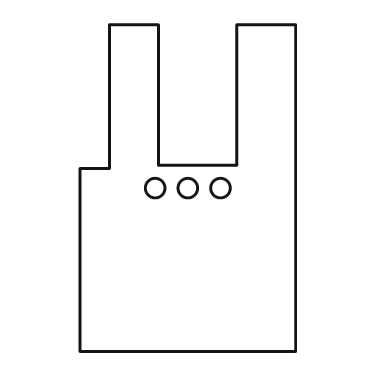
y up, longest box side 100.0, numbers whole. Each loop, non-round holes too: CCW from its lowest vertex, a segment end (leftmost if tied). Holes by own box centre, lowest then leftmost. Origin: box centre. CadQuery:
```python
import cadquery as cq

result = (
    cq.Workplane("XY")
    .moveTo(-33.0, -50.0)
    .lineTo(33.0, -50.0)
    .lineTo(33.0, 50.0)
    .lineTo(15.0, 50.0)
    .lineTo(15.0, 7.0)
    .lineTo(-9.0, 7.0)
    .lineTo(-9.0, 50.0)
    .lineTo(-24.0, 50.0)
    .lineTo(-24.0, 6.0)
    .lineTo(-33.0, 6.0)
    .close()
    .moveTo(-10.0, 0.0)
    .circle(3.0)
    .moveTo(0.0, 0.0)
    .circle(3.0)
    .moveTo(10.0, 0.0)
    .circle(3.0)
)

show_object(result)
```